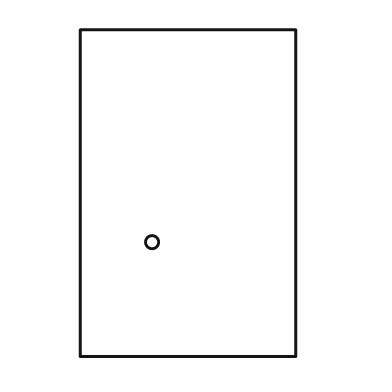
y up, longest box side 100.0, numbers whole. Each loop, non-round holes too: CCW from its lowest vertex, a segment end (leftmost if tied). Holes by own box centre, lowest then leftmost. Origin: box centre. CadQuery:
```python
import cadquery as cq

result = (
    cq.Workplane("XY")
    .moveTo(-33.0, -50.0)
    .lineTo(33.0, -50.0)
    .lineTo(33.0, 50.0)
    .lineTo(-33.0, 50.0)
    .close()
    .moveTo(-11.0, -15.0)
    .circle(2.0)
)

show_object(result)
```